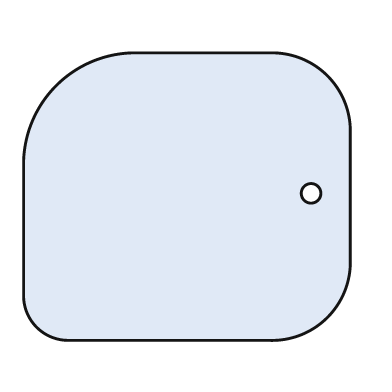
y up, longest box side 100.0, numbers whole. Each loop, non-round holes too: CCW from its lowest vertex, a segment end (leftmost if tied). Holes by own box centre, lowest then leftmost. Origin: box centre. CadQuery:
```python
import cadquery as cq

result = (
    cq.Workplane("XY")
    .moveTo(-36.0, -44.0)
    .lineTo(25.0, -44.0)
    .threePointArc((43.0, -37.0), (50.0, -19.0))
    .lineTo(50.0, 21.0)
    .threePointArc((43.0, 37.0), (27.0, 44.0))
    .lineTo(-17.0, 44.0)
    .threePointArc((-40.0, 34.0), (-50.0, 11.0))
    .lineTo(-50.0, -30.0)
    .threePointArc((-46.0, -40.0), (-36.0, -44.0))
    .close()
    .moveTo(38.0, 1.0)
    .circle(3.0)
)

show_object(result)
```